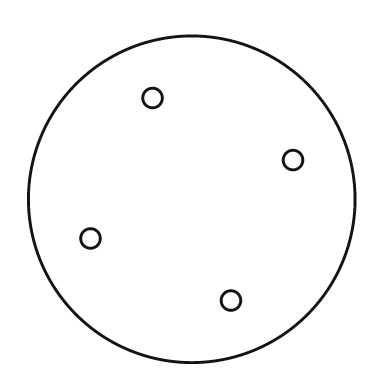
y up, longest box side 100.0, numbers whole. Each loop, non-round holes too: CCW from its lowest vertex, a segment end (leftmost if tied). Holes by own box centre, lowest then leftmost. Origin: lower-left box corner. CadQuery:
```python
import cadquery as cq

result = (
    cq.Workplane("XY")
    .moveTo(50.0, 50.0)
    .circle(50.0)
    .moveTo(62.0, 19.0)
    .circle(3.0)
    .moveTo(19.0, 38.0)
    .circle(3.0)
    .moveTo(81.0, 62.0)
    .circle(3.0)
    .moveTo(38.0, 81.0)
    .circle(3.0)
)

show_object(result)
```